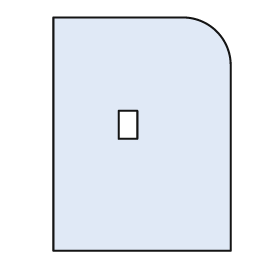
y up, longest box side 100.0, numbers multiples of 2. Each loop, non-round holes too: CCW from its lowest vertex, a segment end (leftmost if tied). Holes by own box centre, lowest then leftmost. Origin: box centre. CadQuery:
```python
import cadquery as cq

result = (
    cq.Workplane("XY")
    .moveTo(-38.0, -50.0)
    .lineTo(38.0, -50.0)
    .lineTo(38.0, 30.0)
    .threePointArc((32.0, 44.0), (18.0, 50.0))
    .lineTo(-38.0, 50.0)
    .close()
    .moveTo(-10.0, -2.0)
    .lineTo(-2.0, -2.0)
    .lineTo(-2.0, 10.0)
    .lineTo(-10.0, 10.0)
    .close()
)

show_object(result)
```